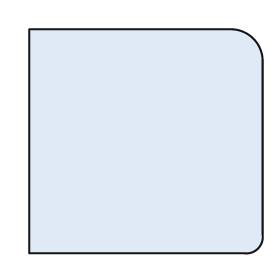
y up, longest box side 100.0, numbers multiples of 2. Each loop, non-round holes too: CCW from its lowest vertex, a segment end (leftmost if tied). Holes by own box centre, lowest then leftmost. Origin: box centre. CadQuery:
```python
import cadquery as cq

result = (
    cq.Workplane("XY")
    .moveTo(-50.0, -48.0)
    .lineTo(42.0, -48.0)
    .threePointArc((48.0, -46.0), (50.0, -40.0))
    .lineTo(50.0, 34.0)
    .threePointArc((46.0, 44.0), (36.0, 48.0))
    .lineTo(-50.0, 48.0)
    .close()
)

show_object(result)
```